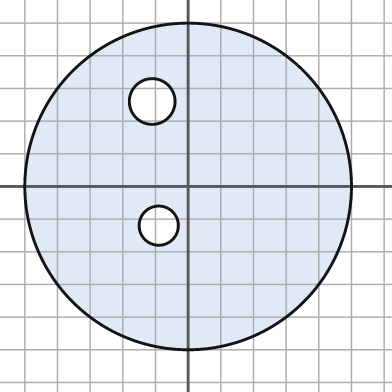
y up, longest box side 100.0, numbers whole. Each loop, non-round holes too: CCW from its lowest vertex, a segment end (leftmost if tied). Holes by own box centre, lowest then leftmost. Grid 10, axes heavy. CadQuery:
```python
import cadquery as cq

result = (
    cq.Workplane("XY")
    .moveTo(0.0, 0.0)
    .circle(50.0)
    .moveTo(-9.0, -12.0)
    .circle(6.0)
    .moveTo(-11.0, 26.0)
    .circle(7.0)
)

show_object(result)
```